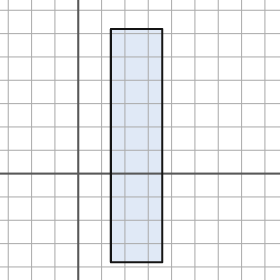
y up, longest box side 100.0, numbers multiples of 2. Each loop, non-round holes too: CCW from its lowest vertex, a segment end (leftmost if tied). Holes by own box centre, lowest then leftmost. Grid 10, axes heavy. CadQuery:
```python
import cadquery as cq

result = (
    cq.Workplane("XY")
    .moveTo(14.0, -38.0)
    .lineTo(36.0, -38.0)
    .lineTo(36.0, 62.0)
    .lineTo(14.0, 62.0)
    .close()
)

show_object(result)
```